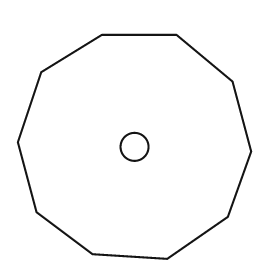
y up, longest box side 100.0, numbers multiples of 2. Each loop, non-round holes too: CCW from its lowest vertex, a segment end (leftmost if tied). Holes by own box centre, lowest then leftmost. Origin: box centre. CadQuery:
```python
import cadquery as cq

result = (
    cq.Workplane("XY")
    .moveTo(14.0, -48.0)
    .lineTo(40.0, -30.0)
    .lineTo(50.0, -2.0)
    .lineTo(42.0, 28.0)
    .lineTo(18.0, 48.0)
    .lineTo(-14.0, 48.0)
    .lineTo(-40.0, 32.0)
    .lineTo(-50.0, 2.0)
    .lineTo(-42.0, -28.0)
    .lineTo(-18.0, -46.0)
    .close()
    .moveTo(0.0, 0.0)
    .circle(6.0)
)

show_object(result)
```